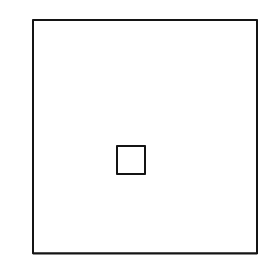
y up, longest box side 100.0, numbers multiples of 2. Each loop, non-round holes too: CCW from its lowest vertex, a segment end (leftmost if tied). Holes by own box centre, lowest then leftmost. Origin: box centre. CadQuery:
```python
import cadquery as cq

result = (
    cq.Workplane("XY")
    .moveTo(-48.0, -50.0)
    .lineTo(48.0, -50.0)
    .lineTo(48.0, 50.0)
    .lineTo(-48.0, 50.0)
    .close()
    .moveTo(-12.0, -16.0)
    .lineTo(0.0, -16.0)
    .lineTo(0.0, -4.0)
    .lineTo(-12.0, -4.0)
    .close()
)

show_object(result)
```